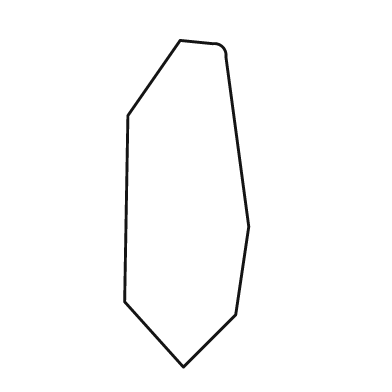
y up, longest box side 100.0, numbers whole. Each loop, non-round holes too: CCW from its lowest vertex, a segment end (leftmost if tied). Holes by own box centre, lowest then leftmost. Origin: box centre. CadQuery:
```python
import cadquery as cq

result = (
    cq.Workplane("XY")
    .moveTo(-1.0, -50.0)
    .lineTo(15.0, -34.0)
    .lineTo(19.0, -7.0)
    .lineTo(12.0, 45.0)
    .threePointArc((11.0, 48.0), (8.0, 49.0))
    .lineTo(-2.0, 50.0)
    .lineTo(-18.0, 27.0)
    .lineTo(-19.0, -30.0)
    .close()
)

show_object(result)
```